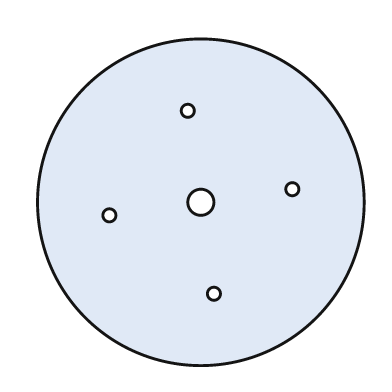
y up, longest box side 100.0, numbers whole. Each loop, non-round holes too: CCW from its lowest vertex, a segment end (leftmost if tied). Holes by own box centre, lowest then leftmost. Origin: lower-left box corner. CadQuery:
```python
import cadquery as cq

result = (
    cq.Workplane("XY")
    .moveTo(50.0, 50.0)
    .circle(50.0)
    .moveTo(54.0, 22.0)
    .circle(2.0)
    .moveTo(22.0, 46.0)
    .circle(2.0)
    .moveTo(50.0, 50.0)
    .circle(4.0)
    .moveTo(78.0, 54.0)
    .circle(2.0)
    .moveTo(46.0, 78.0)
    .circle(2.0)
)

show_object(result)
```